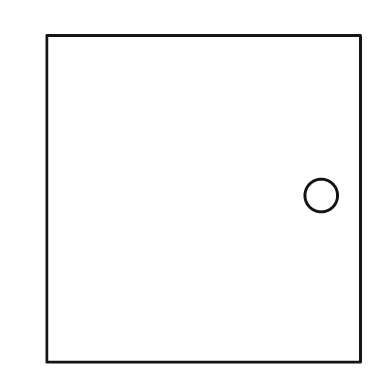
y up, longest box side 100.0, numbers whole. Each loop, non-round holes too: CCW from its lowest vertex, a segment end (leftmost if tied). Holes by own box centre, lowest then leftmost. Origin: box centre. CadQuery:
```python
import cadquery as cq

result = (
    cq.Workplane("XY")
    .moveTo(-48.0, -50.0)
    .lineTo(48.0, -50.0)
    .lineTo(48.0, 50.0)
    .lineTo(-48.0, 50.0)
    .close()
    .moveTo(36.0, 1.0)
    .circle(5.0)
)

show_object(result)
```